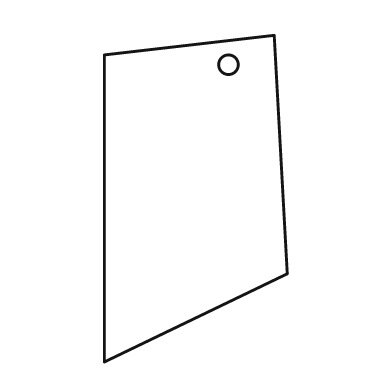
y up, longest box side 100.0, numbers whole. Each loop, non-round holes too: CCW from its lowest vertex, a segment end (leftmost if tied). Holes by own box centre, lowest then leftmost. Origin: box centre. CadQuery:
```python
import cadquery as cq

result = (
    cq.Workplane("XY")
    .moveTo(-28.0, -50.0)
    .lineTo(28.0, -23.0)
    .lineTo(24.0, 50.0)
    .lineTo(-28.0, 44.0)
    .close()
    .moveTo(10.0, 41.0)
    .circle(3.0)
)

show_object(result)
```